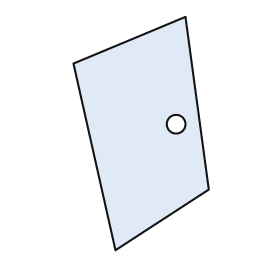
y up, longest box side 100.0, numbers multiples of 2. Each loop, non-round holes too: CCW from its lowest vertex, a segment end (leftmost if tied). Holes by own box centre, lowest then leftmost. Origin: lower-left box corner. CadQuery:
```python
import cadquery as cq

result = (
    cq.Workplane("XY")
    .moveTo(18.0, 0.0)
    .lineTo(58.0, 26.0)
    .lineTo(48.0, 100.0)
    .lineTo(0.0, 80.0)
    .close()
    .moveTo(44.0, 54.0)
    .circle(4.0)
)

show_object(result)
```